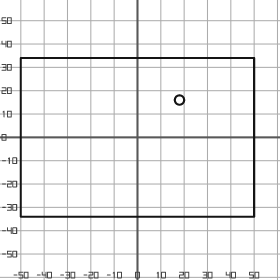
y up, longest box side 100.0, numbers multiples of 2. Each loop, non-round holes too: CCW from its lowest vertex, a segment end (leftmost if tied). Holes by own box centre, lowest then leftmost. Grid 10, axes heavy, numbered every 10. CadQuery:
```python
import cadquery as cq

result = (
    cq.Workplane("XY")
    .moveTo(-50.0, -34.0)
    .lineTo(50.0, -34.0)
    .lineTo(50.0, 34.0)
    .lineTo(-50.0, 34.0)
    .close()
    .moveTo(18.0, 16.0)
    .circle(2.0)
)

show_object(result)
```